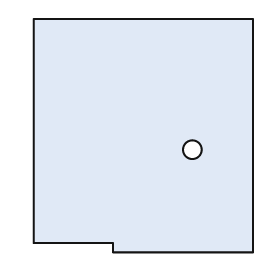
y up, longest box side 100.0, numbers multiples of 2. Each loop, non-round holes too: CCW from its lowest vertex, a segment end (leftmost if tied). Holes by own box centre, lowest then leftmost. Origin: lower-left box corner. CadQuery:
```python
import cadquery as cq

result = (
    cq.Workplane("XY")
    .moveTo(34.0, 0.0)
    .lineTo(94.0, 0.0)
    .lineTo(94.0, 100.0)
    .lineTo(0.0, 100.0)
    .lineTo(0.0, 4.0)
    .lineTo(34.0, 4.0)
    .close()
    .moveTo(68.0, 44.0)
    .circle(4.0)
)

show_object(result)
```